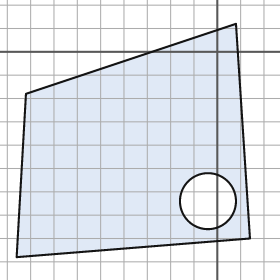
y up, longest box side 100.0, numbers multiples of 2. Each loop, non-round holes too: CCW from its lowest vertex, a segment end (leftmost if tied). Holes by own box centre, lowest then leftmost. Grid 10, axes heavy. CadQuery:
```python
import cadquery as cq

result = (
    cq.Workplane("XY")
    .moveTo(-86.0, -88.0)
    .lineTo(14.0, -80.0)
    .lineTo(8.0, 12.0)
    .lineTo(-82.0, -18.0)
    .close()
    .moveTo(-4.0, -64.0)
    .circle(12.0)
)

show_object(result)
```